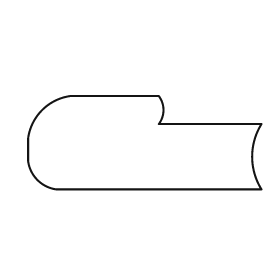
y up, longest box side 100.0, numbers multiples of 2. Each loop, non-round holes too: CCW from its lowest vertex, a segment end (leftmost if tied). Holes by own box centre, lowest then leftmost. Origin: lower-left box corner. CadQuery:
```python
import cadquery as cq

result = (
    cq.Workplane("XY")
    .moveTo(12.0, 0.0)
    .lineTo(100.0, 0.0)
    .threePointArc((96.0, 14.0), (100.0, 28.0))
    .lineTo(56.0, 28.0)
    .threePointArc((58.0, 34.0), (56.0, 40.0))
    .lineTo(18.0, 40.0)
    .threePointArc((6.0, 34.0), (0.0, 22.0))
    .lineTo(0.0, 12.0)
    .threePointArc((4.0, 4.0), (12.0, 0.0))
    .close()
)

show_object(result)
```